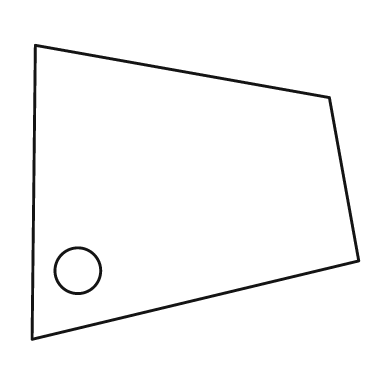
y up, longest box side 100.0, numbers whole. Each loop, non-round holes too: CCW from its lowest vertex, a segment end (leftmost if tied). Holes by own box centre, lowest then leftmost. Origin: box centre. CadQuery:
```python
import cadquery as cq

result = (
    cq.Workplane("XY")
    .moveTo(-50.0, -45.0)
    .lineTo(50.0, -21.0)
    .lineTo(41.0, 29.0)
    .lineTo(-49.0, 45.0)
    .close()
    .moveTo(-36.0, -24.0)
    .circle(7.0)
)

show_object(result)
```